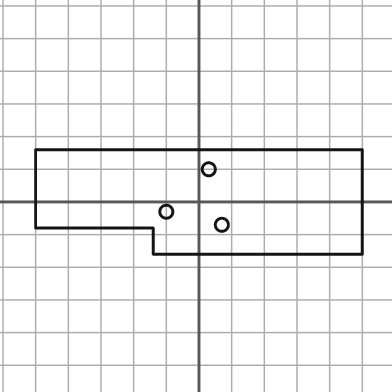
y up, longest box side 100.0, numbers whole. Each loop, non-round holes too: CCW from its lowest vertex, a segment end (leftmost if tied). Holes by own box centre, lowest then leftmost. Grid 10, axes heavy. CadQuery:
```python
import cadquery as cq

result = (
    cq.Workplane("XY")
    .moveTo(-14.0, -16.0)
    .lineTo(50.0, -16.0)
    .lineTo(50.0, 16.0)
    .lineTo(-50.0, 16.0)
    .lineTo(-50.0, -8.0)
    .lineTo(-14.0, -8.0)
    .close()
    .moveTo(7.0, -7.0)
    .circle(2.0)
    .moveTo(-10.0, -3.0)
    .circle(2.0)
    .moveTo(3.0, 10.0)
    .circle(2.0)
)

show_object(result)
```